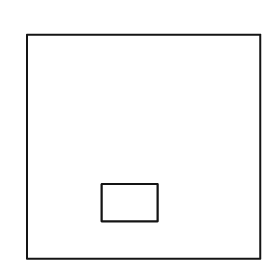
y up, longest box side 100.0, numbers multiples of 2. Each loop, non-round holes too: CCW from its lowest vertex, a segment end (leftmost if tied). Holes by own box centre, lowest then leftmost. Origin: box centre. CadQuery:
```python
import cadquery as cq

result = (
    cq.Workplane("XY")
    .moveTo(-50.0, -48.0)
    .lineTo(50.0, -48.0)
    .lineTo(50.0, 48.0)
    .lineTo(-50.0, 48.0)
    .close()
    .moveTo(-18.0, -32.0)
    .lineTo(6.0, -32.0)
    .lineTo(6.0, -16.0)
    .lineTo(-18.0, -16.0)
    .close()
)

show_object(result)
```